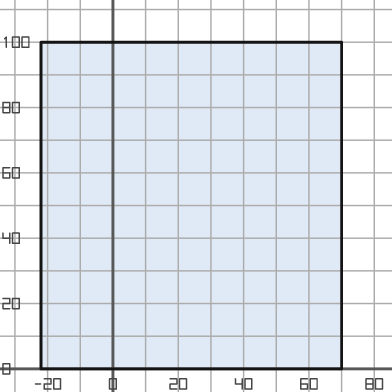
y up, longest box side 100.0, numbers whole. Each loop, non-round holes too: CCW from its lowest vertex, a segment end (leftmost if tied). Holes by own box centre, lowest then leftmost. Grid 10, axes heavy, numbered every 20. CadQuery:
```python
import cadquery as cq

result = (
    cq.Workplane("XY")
    .moveTo(-22.0, 0.0)
    .lineTo(70.0, 0.0)
    .lineTo(70.0, 100.0)
    .lineTo(-22.0, 100.0)
    .close()
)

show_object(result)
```